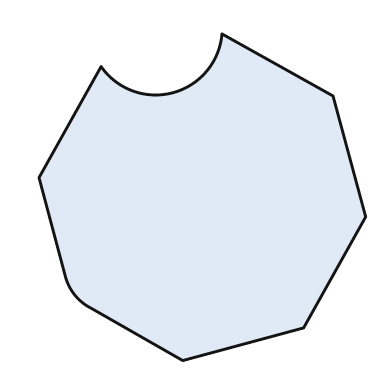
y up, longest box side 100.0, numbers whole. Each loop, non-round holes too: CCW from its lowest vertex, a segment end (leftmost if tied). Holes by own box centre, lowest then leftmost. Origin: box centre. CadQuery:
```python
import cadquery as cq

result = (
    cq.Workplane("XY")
    .moveTo(-6.0, -50.0)
    .lineTo(31.0, -40.0)
    .lineTo(50.0, -6.0)
    .lineTo(40.0, 31.0)
    .lineTo(6.0, 50.0)
    .threePointArc((-9.0, 32.0), (-31.0, 40.0))
    .lineTo(-50.0, 6.0)
    .lineTo(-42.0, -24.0)
    .threePointArc((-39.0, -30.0), (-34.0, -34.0))
    .close()
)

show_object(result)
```